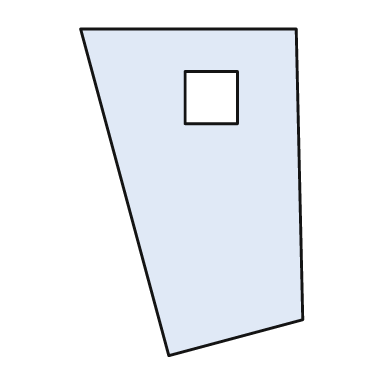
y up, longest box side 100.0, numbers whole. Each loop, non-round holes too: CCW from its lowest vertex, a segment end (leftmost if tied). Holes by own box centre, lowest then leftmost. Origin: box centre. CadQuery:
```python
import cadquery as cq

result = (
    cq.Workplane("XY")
    .moveTo(-7.0, -50.0)
    .lineTo(34.0, -39.0)
    .lineTo(32.0, 50.0)
    .lineTo(-34.0, 50.0)
    .close()
    .moveTo(-2.0, 21.0)
    .lineTo(14.0, 21.0)
    .lineTo(14.0, 37.0)
    .lineTo(-2.0, 37.0)
    .close()
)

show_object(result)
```